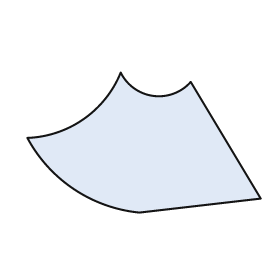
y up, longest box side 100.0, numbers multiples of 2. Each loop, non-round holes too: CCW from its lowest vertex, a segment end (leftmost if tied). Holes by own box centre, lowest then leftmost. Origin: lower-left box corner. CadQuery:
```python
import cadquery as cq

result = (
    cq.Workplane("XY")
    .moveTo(48.0, 0.0)
    .lineTo(100.0, 6.0)
    .lineTo(70.0, 56.0)
    .threePointArc((54.0, 50.0), (40.0, 60.0))
    .threePointArc((24.0, 40.0), (0.0, 32.0))
    .threePointArc((20.0, 10.0), (48.0, 0.0))
    .close()
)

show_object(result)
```